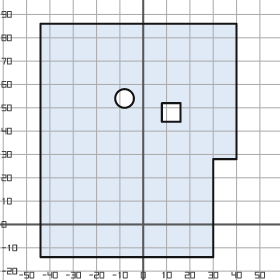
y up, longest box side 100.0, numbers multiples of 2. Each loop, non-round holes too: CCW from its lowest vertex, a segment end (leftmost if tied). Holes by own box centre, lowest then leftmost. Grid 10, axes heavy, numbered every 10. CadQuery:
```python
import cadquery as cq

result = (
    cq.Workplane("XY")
    .moveTo(-44.0, -14.0)
    .lineTo(30.0, -14.0)
    .lineTo(30.0, 28.0)
    .lineTo(40.0, 28.0)
    .lineTo(40.0, 86.0)
    .lineTo(-44.0, 86.0)
    .close()
    .moveTo(8.0, 44.0)
    .lineTo(16.0, 44.0)
    .lineTo(16.0, 52.0)
    .lineTo(8.0, 52.0)
    .close()
    .moveTo(-8.0, 54.0)
    .circle(4.0)
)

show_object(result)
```